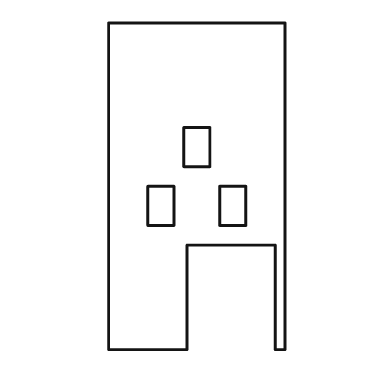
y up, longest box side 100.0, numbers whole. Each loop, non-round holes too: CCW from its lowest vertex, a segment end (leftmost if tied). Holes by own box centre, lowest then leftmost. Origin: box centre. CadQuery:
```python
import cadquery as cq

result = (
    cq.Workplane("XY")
    .moveTo(-27.0, -50.0)
    .lineTo(-3.0, -50.0)
    .lineTo(-3.0, -18.0)
    .lineTo(24.0, -18.0)
    .lineTo(24.0, -50.0)
    .lineTo(27.0, -50.0)
    .lineTo(27.0, 50.0)
    .lineTo(-27.0, 50.0)
    .close()
    .moveTo(-15.0, -12.0)
    .lineTo(-7.0, -12.0)
    .lineTo(-7.0, 0.0)
    .lineTo(-15.0, 0.0)
    .close()
    .moveTo(7.0, -12.0)
    .lineTo(15.0, -12.0)
    .lineTo(15.0, 0.0)
    .lineTo(7.0, 0.0)
    .close()
    .moveTo(-4.0, 6.0)
    .lineTo(4.0, 6.0)
    .lineTo(4.0, 18.0)
    .lineTo(-4.0, 18.0)
    .close()
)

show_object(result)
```